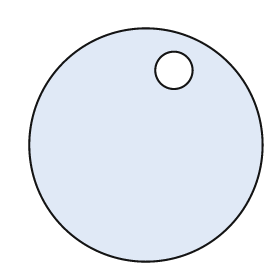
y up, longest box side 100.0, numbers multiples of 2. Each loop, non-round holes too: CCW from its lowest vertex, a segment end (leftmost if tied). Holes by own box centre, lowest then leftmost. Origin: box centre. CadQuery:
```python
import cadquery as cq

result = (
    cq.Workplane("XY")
    .moveTo(0.0, 0.0)
    .circle(50.0)
    .moveTo(12.0, 32.0)
    .circle(8.0)
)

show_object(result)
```